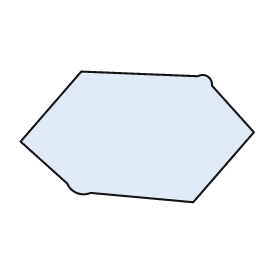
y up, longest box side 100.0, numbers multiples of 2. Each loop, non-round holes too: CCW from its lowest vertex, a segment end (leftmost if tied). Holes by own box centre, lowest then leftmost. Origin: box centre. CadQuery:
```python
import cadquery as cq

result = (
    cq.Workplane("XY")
    .moveTo(24.0, -28.0)
    .lineTo(50.0, 2.0)
    .lineTo(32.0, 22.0)
    .threePointArc((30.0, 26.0), (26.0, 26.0))
    .lineTo(-24.0, 28.0)
    .lineTo(-50.0, -2.0)
    .lineTo(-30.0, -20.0)
    .threePointArc((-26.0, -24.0), (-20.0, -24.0))
    .close()
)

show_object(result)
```